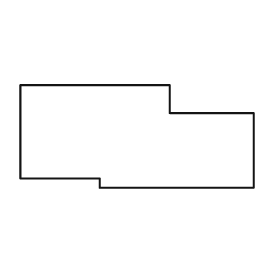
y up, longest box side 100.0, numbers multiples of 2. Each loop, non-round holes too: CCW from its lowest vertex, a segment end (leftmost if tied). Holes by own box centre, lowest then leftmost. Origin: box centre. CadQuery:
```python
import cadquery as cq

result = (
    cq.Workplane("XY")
    .moveTo(-16.0, -22.0)
    .lineTo(50.0, -22.0)
    .lineTo(50.0, 10.0)
    .lineTo(14.0, 10.0)
    .lineTo(14.0, 22.0)
    .lineTo(-50.0, 22.0)
    .lineTo(-50.0, -18.0)
    .lineTo(-16.0, -18.0)
    .close()
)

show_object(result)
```